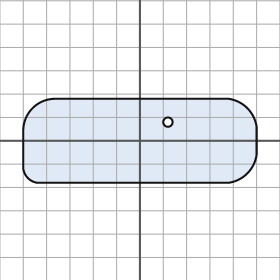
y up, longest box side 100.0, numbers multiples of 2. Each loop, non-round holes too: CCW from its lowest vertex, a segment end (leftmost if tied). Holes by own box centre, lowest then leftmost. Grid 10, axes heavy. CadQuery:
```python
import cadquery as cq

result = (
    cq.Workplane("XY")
    .moveTo(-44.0, -18.0)
    .lineTo(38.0, -18.0)
    .threePointArc((46.0, -14.0), (50.0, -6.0))
    .lineTo(50.0, 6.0)
    .threePointArc((46.0, 14.0), (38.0, 18.0))
    .lineTo(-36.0, 18.0)
    .threePointArc((-46.0, 14.0), (-50.0, 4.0))
    .lineTo(-50.0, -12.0)
    .threePointArc((-48.0, -16.0), (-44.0, -18.0))
    .close()
    .moveTo(12.0, 8.0)
    .circle(2.0)
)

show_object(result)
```